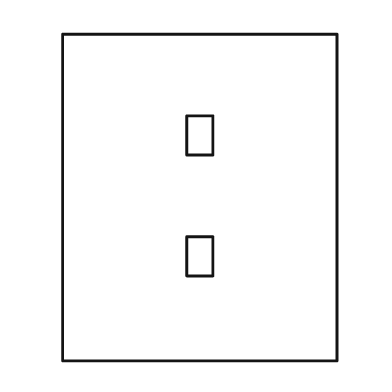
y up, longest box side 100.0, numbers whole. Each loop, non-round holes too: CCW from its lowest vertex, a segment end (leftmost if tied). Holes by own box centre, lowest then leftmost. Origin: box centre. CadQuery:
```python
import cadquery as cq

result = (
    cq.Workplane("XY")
    .moveTo(-42.0, -50.0)
    .lineTo(42.0, -50.0)
    .lineTo(42.0, 50.0)
    .lineTo(-42.0, 50.0)
    .close()
    .moveTo(-4.0, -24.0)
    .lineTo(4.0, -24.0)
    .lineTo(4.0, -12.0)
    .lineTo(-4.0, -12.0)
    .close()
    .moveTo(-4.0, 13.0)
    .lineTo(4.0, 13.0)
    .lineTo(4.0, 25.0)
    .lineTo(-4.0, 25.0)
    .close()
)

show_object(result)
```